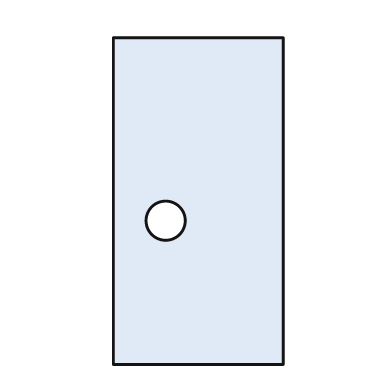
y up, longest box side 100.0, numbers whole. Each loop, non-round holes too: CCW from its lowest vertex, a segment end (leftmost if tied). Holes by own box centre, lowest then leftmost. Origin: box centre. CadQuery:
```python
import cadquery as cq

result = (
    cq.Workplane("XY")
    .moveTo(-26.0, -50.0)
    .lineTo(26.0, -50.0)
    .lineTo(26.0, 50.0)
    .lineTo(-26.0, 50.0)
    .close()
    .moveTo(-10.0, -6.0)
    .circle(6.0)
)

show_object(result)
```